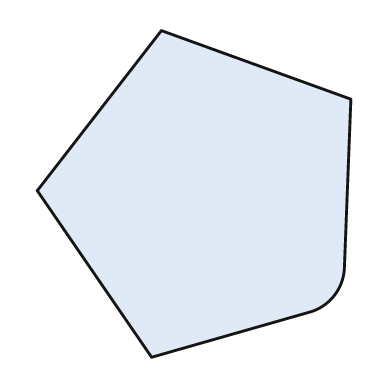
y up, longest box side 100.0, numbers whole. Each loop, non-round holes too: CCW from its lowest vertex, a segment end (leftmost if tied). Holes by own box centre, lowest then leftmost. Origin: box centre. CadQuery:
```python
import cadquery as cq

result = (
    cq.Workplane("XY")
    .moveTo(-13.0, -50.0)
    .lineTo(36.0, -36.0)
    .threePointArc((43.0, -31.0), (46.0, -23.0))
    .lineTo(48.0, 29.0)
    .lineTo(-10.0, 50.0)
    .lineTo(-48.0, 1.0)
    .close()
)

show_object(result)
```